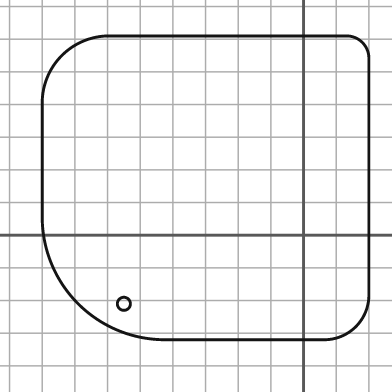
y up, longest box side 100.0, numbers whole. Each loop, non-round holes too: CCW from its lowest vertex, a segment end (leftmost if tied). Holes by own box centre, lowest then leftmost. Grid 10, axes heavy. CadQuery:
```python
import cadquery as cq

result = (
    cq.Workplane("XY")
    .moveTo(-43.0, -32.0)
    .lineTo(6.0, -32.0)
    .threePointArc((16.0, -28.0), (20.0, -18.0))
    .lineTo(20.0, 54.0)
    .threePointArc((18.0, 59.0), (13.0, 61.0))
    .lineTo(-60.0, 61.0)
    .threePointArc((-74.0, 55.0), (-80.0, 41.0))
    .lineTo(-80.0, 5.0)
    .threePointArc((-69.0, -21.0), (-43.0, -32.0))
    .close()
    .moveTo(-55.0, -21.0)
    .circle(2.0)
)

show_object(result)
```